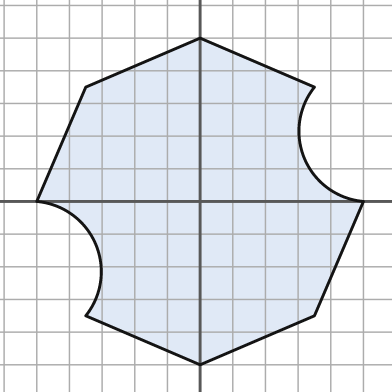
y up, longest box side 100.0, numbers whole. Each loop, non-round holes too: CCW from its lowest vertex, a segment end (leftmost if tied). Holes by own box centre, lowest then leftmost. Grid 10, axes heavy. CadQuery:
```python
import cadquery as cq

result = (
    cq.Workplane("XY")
    .moveTo(0.0, -50.0)
    .lineTo(35.0, -35.0)
    .lineTo(50.0, 0.0)
    .threePointArc((32.0, 13.0), (35.0, 35.0))
    .lineTo(0.0, 50.0)
    .lineTo(-35.0, 35.0)
    .lineTo(-50.0, 0.0)
    .threePointArc((-32.0, -13.0), (-35.0, -35.0))
    .close()
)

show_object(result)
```